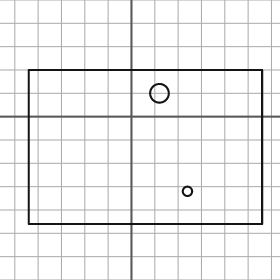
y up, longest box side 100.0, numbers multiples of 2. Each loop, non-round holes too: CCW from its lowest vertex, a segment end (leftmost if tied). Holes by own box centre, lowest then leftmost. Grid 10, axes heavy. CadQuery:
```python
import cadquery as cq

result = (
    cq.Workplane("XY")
    .moveTo(-44.0, -46.0)
    .lineTo(56.0, -46.0)
    .lineTo(56.0, 20.0)
    .lineTo(-44.0, 20.0)
    .close()
    .moveTo(24.0, -32.0)
    .circle(2.0)
    .moveTo(12.0, 10.0)
    .circle(4.0)
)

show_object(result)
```